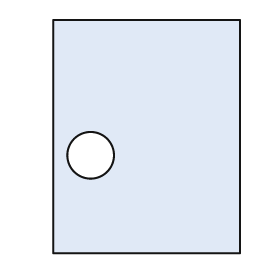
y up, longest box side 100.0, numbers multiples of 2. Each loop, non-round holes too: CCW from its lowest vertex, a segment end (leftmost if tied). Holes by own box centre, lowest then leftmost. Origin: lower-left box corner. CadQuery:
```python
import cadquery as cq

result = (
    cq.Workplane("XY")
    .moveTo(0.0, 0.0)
    .lineTo(80.0, 0.0)
    .lineTo(80.0, 100.0)
    .lineTo(0.0, 100.0)
    .close()
    .moveTo(16.0, 42.0)
    .circle(10.0)
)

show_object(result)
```